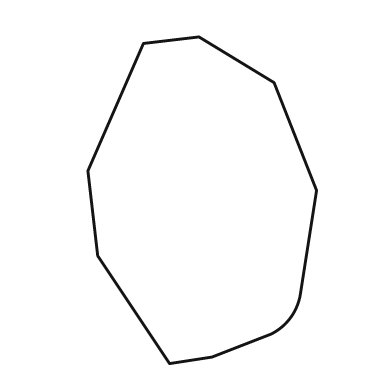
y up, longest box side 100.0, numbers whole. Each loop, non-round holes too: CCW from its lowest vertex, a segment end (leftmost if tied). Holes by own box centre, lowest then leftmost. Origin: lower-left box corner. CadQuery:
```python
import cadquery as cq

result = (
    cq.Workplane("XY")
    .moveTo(25.0, 0.0)
    .lineTo(38.0, 2.0)
    .lineTo(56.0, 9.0)
    .threePointArc((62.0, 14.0), (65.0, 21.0))
    .lineTo(70.0, 53.0)
    .lineTo(57.0, 86.0)
    .lineTo(34.0, 100.0)
    .lineTo(17.0, 98.0)
    .lineTo(0.0, 59.0)
    .lineTo(3.0, 33.0)
    .close()
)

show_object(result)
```